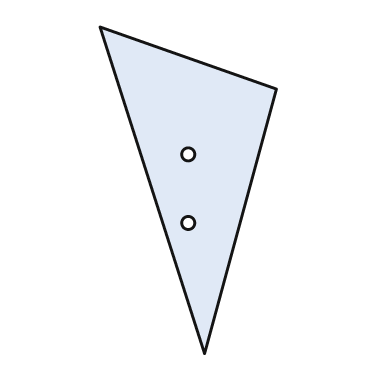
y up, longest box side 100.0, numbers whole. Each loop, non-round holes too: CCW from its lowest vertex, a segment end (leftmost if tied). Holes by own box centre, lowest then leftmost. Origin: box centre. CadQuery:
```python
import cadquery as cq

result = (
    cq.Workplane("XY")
    .moveTo(5.0, -50.0)
    .lineTo(27.0, 31.0)
    .lineTo(-27.0, 50.0)
    .close()
    .moveTo(0.0, -10.0)
    .circle(2.0)
    .moveTo(0.0, 11.0)
    .circle(2.0)
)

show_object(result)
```